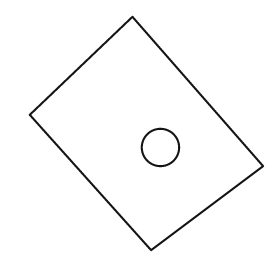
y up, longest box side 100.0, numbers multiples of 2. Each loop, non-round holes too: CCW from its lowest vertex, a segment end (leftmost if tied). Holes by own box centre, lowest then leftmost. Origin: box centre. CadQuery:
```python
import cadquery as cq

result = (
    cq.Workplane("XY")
    .moveTo(2.0, -50.0)
    .lineTo(50.0, -14.0)
    .lineTo(-6.0, 50.0)
    .lineTo(-50.0, 8.0)
    .close()
    .moveTo(6.0, -6.0)
    .circle(8.0)
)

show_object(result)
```